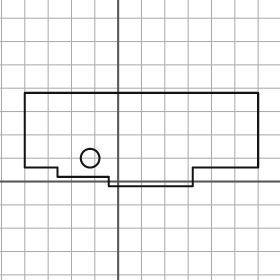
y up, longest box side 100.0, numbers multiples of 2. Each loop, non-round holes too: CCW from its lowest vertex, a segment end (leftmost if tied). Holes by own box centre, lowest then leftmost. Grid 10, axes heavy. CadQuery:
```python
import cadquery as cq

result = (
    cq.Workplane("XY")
    .moveTo(-4.0, -2.0)
    .lineTo(32.0, -2.0)
    .lineTo(32.0, 6.0)
    .lineTo(60.0, 6.0)
    .lineTo(60.0, 38.0)
    .lineTo(-40.0, 38.0)
    .lineTo(-40.0, 6.0)
    .lineTo(-26.0, 6.0)
    .lineTo(-26.0, 2.0)
    .lineTo(-4.0, 2.0)
    .close()
    .moveTo(-12.0, 10.0)
    .circle(4.0)
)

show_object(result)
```